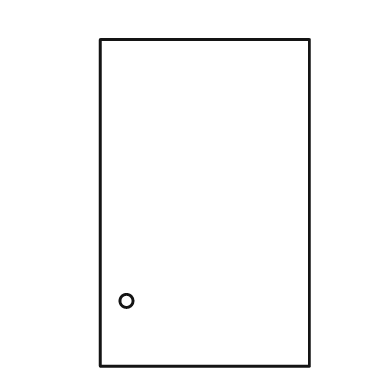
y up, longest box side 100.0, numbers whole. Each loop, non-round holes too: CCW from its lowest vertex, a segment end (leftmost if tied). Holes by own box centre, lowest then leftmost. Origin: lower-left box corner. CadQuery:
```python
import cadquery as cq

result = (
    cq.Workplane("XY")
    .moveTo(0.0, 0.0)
    .lineTo(64.0, 0.0)
    .lineTo(64.0, 100.0)
    .lineTo(0.0, 100.0)
    .close()
    .moveTo(8.0, 20.0)
    .circle(2.0)
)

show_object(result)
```